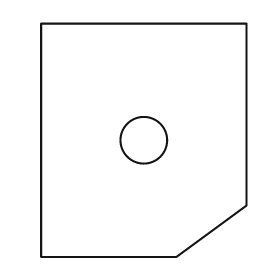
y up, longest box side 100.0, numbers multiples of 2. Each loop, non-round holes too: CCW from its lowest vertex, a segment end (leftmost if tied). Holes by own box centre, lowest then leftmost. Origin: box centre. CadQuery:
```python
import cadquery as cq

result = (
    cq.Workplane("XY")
    .moveTo(-44.0, -50.0)
    .lineTo(14.0, -50.0)
    .lineTo(44.0, -28.0)
    .lineTo(44.0, 50.0)
    .lineTo(-44.0, 50.0)
    .close()
    .moveTo(0.0, 0.0)
    .circle(10.0)
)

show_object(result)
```